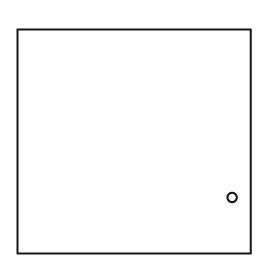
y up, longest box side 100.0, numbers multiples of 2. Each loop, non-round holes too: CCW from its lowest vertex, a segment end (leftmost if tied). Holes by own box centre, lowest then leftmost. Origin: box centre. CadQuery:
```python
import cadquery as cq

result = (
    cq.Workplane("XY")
    .moveTo(-50.0, -48.0)
    .lineTo(50.0, -48.0)
    .lineTo(50.0, 48.0)
    .lineTo(-50.0, 48.0)
    .close()
    .moveTo(42.0, -24.0)
    .circle(2.0)
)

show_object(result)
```